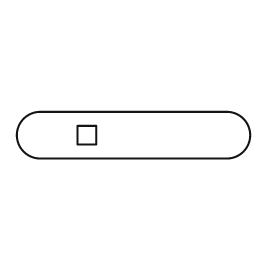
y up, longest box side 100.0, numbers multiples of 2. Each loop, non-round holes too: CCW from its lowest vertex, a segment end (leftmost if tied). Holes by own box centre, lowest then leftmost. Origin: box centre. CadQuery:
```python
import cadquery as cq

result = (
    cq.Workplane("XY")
    .moveTo(-40.0, -10.0)
    .lineTo(40.0, -10.0)
    .threePointArc((50.0, 0.0), (40.0, 10.0))
    .lineTo(-40.0, 10.0)
    .threePointArc((-50.0, 0.0), (-40.0, -10.0))
    .close()
    .moveTo(-24.0, -4.0)
    .lineTo(-16.0, -4.0)
    .lineTo(-16.0, 4.0)
    .lineTo(-24.0, 4.0)
    .close()
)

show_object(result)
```